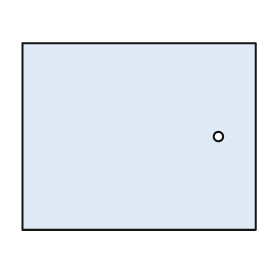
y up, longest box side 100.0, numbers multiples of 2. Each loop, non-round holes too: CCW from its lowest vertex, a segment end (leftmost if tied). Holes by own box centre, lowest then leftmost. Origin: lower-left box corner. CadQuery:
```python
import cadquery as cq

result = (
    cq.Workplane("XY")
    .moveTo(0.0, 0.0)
    .lineTo(100.0, 0.0)
    .lineTo(100.0, 80.0)
    .lineTo(0.0, 80.0)
    .close()
    .moveTo(84.0, 40.0)
    .circle(2.0)
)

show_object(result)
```